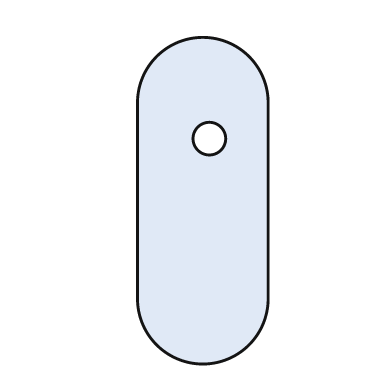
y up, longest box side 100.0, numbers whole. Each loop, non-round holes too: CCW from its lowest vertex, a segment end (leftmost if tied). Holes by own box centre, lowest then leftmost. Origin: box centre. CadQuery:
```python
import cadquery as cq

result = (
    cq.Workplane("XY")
    .moveTo(-20.0, -30.0)
    .threePointArc((0.0, -50.0), (20.0, -30.0))
    .lineTo(20.0, 30.0)
    .threePointArc((0.0, 50.0), (-20.0, 30.0))
    .close()
    .moveTo(2.0, 19.0)
    .circle(5.0)
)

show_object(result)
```